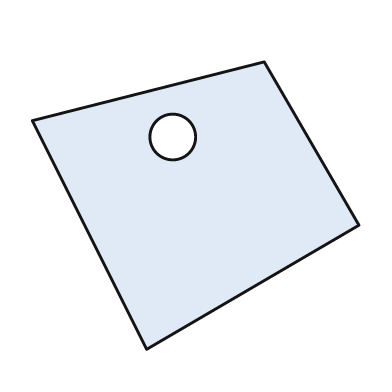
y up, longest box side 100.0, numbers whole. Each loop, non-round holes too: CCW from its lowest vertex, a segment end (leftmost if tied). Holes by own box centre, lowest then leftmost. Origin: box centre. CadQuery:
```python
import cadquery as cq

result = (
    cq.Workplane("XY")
    .moveTo(-15.0, -44.0)
    .lineTo(50.0, -6.0)
    .lineTo(21.0, 44.0)
    .lineTo(-50.0, 26.0)
    .close()
    .moveTo(-7.0, 21.0)
    .circle(7.0)
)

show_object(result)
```